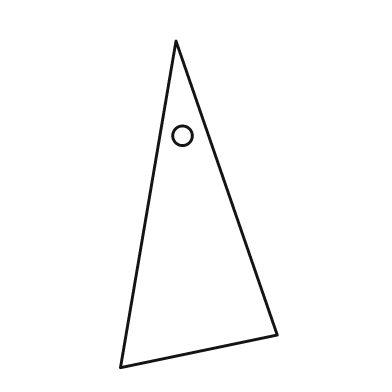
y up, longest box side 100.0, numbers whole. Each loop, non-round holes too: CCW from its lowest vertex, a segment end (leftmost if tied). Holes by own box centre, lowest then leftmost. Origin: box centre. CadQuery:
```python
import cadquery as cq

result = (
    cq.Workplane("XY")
    .moveTo(-24.0, -50.0)
    .lineTo(24.0, -40.0)
    .lineTo(-7.0, 50.0)
    .close()
    .moveTo(-5.0, 21.0)
    .circle(3.0)
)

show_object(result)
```